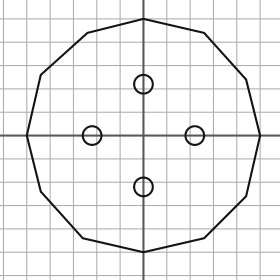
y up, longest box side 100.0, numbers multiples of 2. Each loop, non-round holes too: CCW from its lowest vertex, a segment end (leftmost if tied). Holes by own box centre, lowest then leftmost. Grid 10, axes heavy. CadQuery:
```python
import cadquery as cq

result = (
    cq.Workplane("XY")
    .moveTo(0.0, -50.0)
    .lineTo(26.0, -44.0)
    .lineTo(44.0, -26.0)
    .lineTo(50.0, 0.0)
    .lineTo(44.0, 24.0)
    .lineTo(26.0, 44.0)
    .lineTo(0.0, 50.0)
    .lineTo(-24.0, 44.0)
    .lineTo(-44.0, 26.0)
    .lineTo(-50.0, 0.0)
    .lineTo(-44.0, -24.0)
    .lineTo(-26.0, -44.0)
    .close()
    .moveTo(0.0, -22.0)
    .circle(4.0)
    .moveTo(-22.0, 0.0)
    .circle(4.0)
    .moveTo(22.0, 0.0)
    .circle(4.0)
    .moveTo(0.0, 22.0)
    .circle(4.0)
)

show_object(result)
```